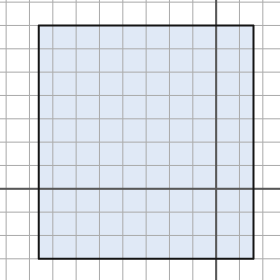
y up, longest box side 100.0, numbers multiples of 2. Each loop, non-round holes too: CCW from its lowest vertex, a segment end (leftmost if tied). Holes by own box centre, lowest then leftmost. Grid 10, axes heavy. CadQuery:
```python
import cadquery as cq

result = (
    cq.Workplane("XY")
    .moveTo(-76.0, -30.0)
    .lineTo(16.0, -30.0)
    .lineTo(16.0, 70.0)
    .lineTo(-76.0, 70.0)
    .close()
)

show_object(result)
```